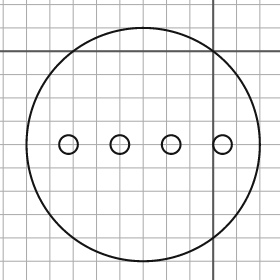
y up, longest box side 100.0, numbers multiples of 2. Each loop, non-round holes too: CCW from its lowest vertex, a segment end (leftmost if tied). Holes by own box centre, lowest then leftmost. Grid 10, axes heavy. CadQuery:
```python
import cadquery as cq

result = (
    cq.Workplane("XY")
    .moveTo(-30.0, -40.0)
    .circle(50.0)
    .moveTo(-62.0, -40.0)
    .circle(4.0)
    .moveTo(-40.0, -40.0)
    .circle(4.0)
    .moveTo(-18.0, -40.0)
    .circle(4.0)
    .moveTo(4.0, -40.0)
    .circle(4.0)
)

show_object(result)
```